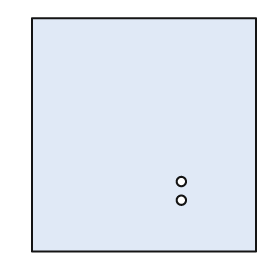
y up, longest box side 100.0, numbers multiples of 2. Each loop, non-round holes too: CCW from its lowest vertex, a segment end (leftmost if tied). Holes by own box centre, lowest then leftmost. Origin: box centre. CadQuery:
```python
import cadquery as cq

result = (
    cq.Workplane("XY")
    .moveTo(-48.0, -50.0)
    .lineTo(48.0, -50.0)
    .lineTo(48.0, 50.0)
    .lineTo(-48.0, 50.0)
    .close()
    .moveTo(16.0, -28.0)
    .circle(2.0)
    .moveTo(16.0, -20.0)
    .circle(2.0)
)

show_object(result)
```